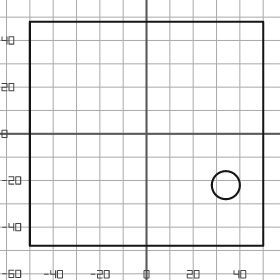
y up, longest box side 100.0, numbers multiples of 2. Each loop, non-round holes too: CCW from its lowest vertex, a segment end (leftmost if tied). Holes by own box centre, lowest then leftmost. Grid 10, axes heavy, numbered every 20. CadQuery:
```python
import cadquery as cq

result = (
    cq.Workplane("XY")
    .moveTo(-50.0, -48.0)
    .lineTo(50.0, -48.0)
    .lineTo(50.0, 48.0)
    .lineTo(-50.0, 48.0)
    .close()
    .moveTo(34.0, -22.0)
    .circle(6.0)
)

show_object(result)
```